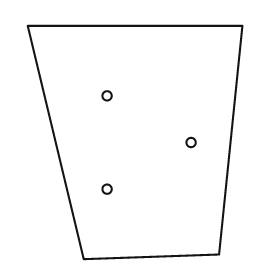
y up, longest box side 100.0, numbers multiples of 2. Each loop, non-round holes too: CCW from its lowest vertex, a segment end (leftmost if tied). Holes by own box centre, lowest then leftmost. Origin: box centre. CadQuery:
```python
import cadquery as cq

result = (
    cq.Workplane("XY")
    .moveTo(-22.0, -50.0)
    .lineTo(36.0, -48.0)
    .lineTo(46.0, 50.0)
    .lineTo(-46.0, 50.0)
    .close()
    .moveTo(-12.0, -20.0)
    .circle(2.0)
    .moveTo(24.0, 0.0)
    .circle(2.0)
    .moveTo(-12.0, 20.0)
    .circle(2.0)
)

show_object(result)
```